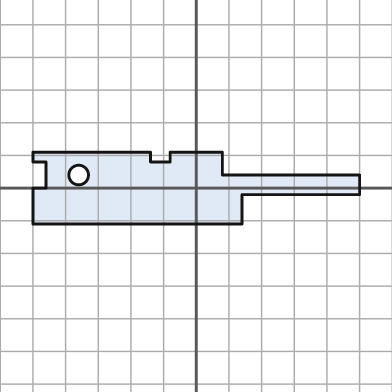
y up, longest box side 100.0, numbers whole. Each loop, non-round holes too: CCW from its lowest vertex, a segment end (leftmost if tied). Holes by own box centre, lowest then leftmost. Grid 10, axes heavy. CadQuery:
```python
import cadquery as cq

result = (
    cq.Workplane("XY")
    .moveTo(-50.0, -11.0)
    .lineTo(14.0, -11.0)
    .lineTo(14.0, -2.0)
    .lineTo(50.0, -2.0)
    .lineTo(50.0, 4.0)
    .lineTo(8.0, 4.0)
    .lineTo(8.0, 11.0)
    .lineTo(-8.0, 11.0)
    .lineTo(-8.0, 8.0)
    .lineTo(-14.0, 8.0)
    .lineTo(-14.0, 11.0)
    .lineTo(-50.0, 11.0)
    .lineTo(-50.0, 8.0)
    .lineTo(-46.0, 8.0)
    .lineTo(-46.0, 0.0)
    .lineTo(-50.0, 0.0)
    .close()
    .moveTo(-36.0, 4.0)
    .circle(3.0)
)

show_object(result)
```